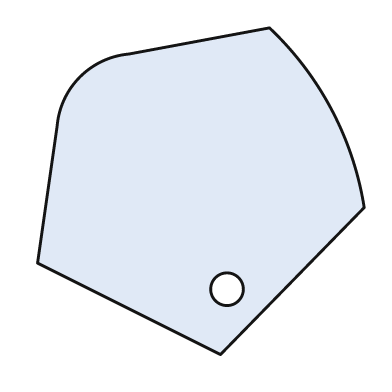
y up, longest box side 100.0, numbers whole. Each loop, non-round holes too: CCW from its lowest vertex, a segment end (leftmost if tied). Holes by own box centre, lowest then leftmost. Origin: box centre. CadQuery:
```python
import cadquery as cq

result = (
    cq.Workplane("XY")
    .moveTo(6.0, -50.0)
    .lineTo(50.0, -5.0)
    .threePointArc((40.0, 25.0), (21.0, 50.0))
    .lineTo(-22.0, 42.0)
    .threePointArc((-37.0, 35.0), (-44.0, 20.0))
    .lineTo(-50.0, -22.0)
    .close()
    .moveTo(8.0, -30.0)
    .circle(5.0)
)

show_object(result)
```